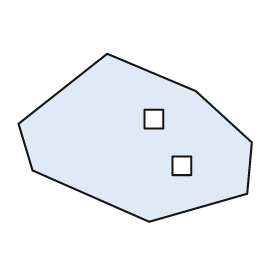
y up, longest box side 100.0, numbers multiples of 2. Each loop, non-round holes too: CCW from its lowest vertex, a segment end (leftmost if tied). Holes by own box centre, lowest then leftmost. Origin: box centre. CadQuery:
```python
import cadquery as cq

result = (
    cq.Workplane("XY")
    .moveTo(6.0, -36.0)
    .lineTo(48.0, -24.0)
    .lineTo(50.0, -2.0)
    .lineTo(26.0, 20.0)
    .lineTo(-12.0, 36.0)
    .lineTo(-50.0, 6.0)
    .lineTo(-44.0, -14.0)
    .close()
    .moveTo(16.0, -16.0)
    .lineTo(24.0, -16.0)
    .lineTo(24.0, -8.0)
    .lineTo(16.0, -8.0)
    .close()
    .moveTo(4.0, 4.0)
    .lineTo(12.0, 4.0)
    .lineTo(12.0, 12.0)
    .lineTo(4.0, 12.0)
    .close()
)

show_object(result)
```